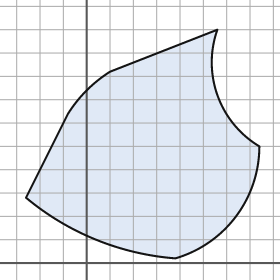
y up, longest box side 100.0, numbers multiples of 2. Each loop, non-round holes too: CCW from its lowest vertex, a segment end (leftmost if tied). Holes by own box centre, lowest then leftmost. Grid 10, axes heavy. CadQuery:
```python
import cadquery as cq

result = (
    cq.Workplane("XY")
    .moveTo(38.0, 2.0)
    .threePointArc((64.0, 20.0), (74.0, 50.0))
    .threePointArc((56.0, 72.0), (56.0, 100.0))
    .lineTo(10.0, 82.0)
    .threePointArc((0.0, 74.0), (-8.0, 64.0))
    .lineTo(-26.0, 28.0)
    .threePointArc((4.0, 10.0), (38.0, 2.0))
    .close()
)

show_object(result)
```